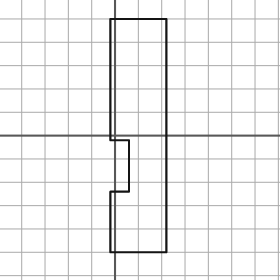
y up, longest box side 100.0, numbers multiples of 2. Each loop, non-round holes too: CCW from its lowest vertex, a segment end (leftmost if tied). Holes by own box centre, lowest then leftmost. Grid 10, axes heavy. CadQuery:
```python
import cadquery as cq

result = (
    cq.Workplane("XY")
    .moveTo(-2.0, -50.0)
    .lineTo(22.0, -50.0)
    .lineTo(22.0, 50.0)
    .lineTo(-2.0, 50.0)
    .lineTo(-2.0, -2.0)
    .lineTo(6.0, -2.0)
    .lineTo(6.0, -24.0)
    .lineTo(-2.0, -24.0)
    .close()
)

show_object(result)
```